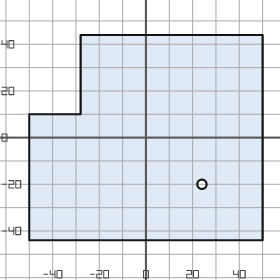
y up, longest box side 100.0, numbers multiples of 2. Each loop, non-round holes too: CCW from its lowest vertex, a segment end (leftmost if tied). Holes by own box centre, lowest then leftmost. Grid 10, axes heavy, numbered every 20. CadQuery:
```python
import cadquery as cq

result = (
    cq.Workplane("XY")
    .moveTo(-50.0, -44.0)
    .lineTo(50.0, -44.0)
    .lineTo(50.0, 44.0)
    .lineTo(-28.0, 44.0)
    .lineTo(-28.0, 10.0)
    .lineTo(-50.0, 10.0)
    .close()
    .moveTo(24.0, -20.0)
    .circle(2.0)
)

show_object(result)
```